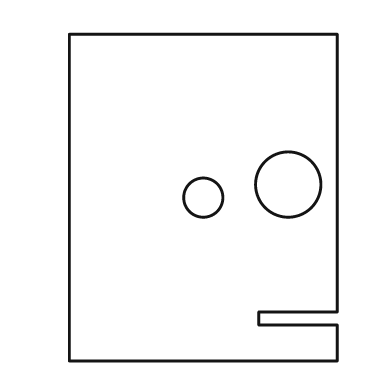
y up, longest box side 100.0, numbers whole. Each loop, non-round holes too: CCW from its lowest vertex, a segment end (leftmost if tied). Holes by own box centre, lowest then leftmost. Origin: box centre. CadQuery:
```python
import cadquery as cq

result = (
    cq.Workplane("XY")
    .moveTo(-41.0, -50.0)
    .lineTo(41.0, -50.0)
    .lineTo(41.0, -39.0)
    .lineTo(17.0, -39.0)
    .lineTo(17.0, -35.0)
    .lineTo(41.0, -35.0)
    .lineTo(41.0, 50.0)
    .lineTo(-41.0, 50.0)
    .close()
    .moveTo(0.0, 0.0)
    .circle(6.0)
    .moveTo(26.0, 4.0)
    .circle(10.0)
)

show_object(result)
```